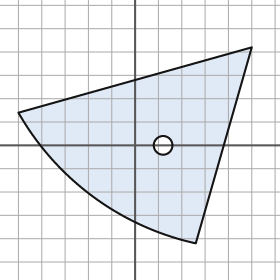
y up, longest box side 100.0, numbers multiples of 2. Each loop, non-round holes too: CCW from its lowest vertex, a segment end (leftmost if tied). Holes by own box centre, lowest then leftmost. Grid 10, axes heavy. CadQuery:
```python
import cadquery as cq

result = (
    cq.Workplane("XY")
    .moveTo(26.0, -42.0)
    .lineTo(50.0, 42.0)
    .lineTo(-50.0, 14.0)
    .threePointArc((-18.0, -22.0), (26.0, -42.0))
    .close()
    .moveTo(12.0, 0.0)
    .circle(4.0)
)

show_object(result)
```